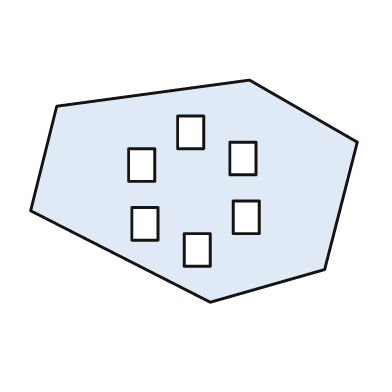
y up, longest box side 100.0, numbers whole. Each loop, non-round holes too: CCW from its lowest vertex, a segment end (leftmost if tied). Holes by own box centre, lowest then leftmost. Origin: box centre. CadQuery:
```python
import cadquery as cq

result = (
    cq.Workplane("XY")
    .moveTo(5.0, -34.0)
    .lineTo(40.0, -24.0)
    .lineTo(50.0, 15.0)
    .lineTo(17.0, 34.0)
    .lineTo(-42.0, 26.0)
    .lineTo(-50.0, -6.0)
    .close()
    .moveTo(-3.0, -23.0)
    .lineTo(5.0, -23.0)
    .lineTo(5.0, -13.0)
    .lineTo(-3.0, -13.0)
    .close()
    .moveTo(-19.0, -15.0)
    .lineTo(-11.0, -15.0)
    .lineTo(-11.0, -5.0)
    .lineTo(-19.0, -5.0)
    .close()
    .moveTo(12.0, -13.0)
    .lineTo(20.0, -13.0)
    .lineTo(20.0, -3.0)
    .lineTo(12.0, -3.0)
    .close()
    .moveTo(-20.0, 3.0)
    .lineTo(-12.0, 3.0)
    .lineTo(-12.0, 13.0)
    .lineTo(-20.0, 13.0)
    .close()
    .moveTo(11.0, 5.0)
    .lineTo(19.0, 5.0)
    .lineTo(19.0, 15.0)
    .lineTo(11.0, 15.0)
    .close()
    .moveTo(-5.0, 13.0)
    .lineTo(3.0, 13.0)
    .lineTo(3.0, 23.0)
    .lineTo(-5.0, 23.0)
    .close()
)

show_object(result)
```